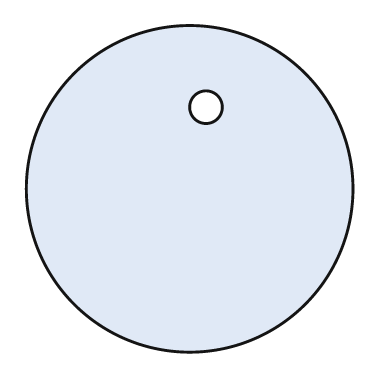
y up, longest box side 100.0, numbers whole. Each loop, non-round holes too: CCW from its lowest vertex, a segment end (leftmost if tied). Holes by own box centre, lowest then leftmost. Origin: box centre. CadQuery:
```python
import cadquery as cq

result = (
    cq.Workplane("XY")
    .moveTo(0.0, 0.0)
    .circle(50.0)
    .moveTo(5.0, 25.0)
    .circle(5.0)
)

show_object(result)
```